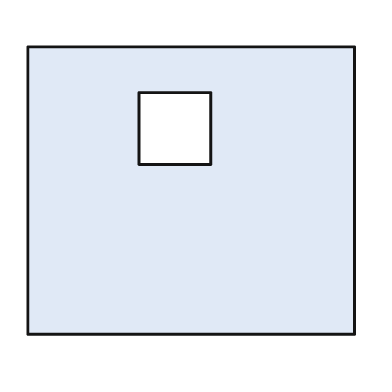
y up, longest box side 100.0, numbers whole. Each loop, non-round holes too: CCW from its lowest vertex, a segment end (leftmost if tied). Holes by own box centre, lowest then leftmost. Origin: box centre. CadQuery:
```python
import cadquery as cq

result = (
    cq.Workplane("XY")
    .moveTo(-50.0, -44.0)
    .lineTo(50.0, -44.0)
    .lineTo(50.0, 44.0)
    .lineTo(-50.0, 44.0)
    .close()
    .moveTo(-16.0, 8.0)
    .lineTo(6.0, 8.0)
    .lineTo(6.0, 30.0)
    .lineTo(-16.0, 30.0)
    .close()
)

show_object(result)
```